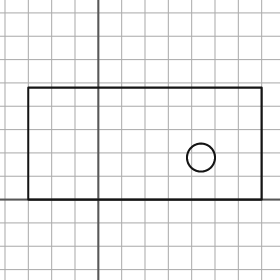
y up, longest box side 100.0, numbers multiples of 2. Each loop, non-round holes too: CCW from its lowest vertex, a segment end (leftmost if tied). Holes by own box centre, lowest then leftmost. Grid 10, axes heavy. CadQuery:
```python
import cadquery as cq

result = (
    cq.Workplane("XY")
    .moveTo(-30.0, 0.0)
    .lineTo(70.0, 0.0)
    .lineTo(70.0, 48.0)
    .lineTo(-30.0, 48.0)
    .close()
    .moveTo(44.0, 18.0)
    .circle(6.0)
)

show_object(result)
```